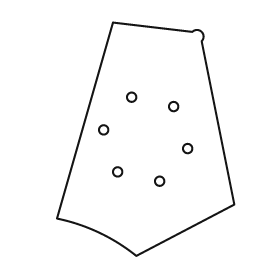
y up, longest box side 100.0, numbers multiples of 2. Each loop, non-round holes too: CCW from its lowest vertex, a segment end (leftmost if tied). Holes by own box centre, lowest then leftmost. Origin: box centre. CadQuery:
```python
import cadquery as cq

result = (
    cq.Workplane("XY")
    .moveTo(-4.0, -50.0)
    .lineTo(38.0, -28.0)
    .lineTo(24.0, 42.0)
    .threePointArc((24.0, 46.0), (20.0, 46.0))
    .lineTo(-14.0, 50.0)
    .lineTo(-38.0, -34.0)
    .threePointArc((-20.0, -40.0), (-4.0, -50.0))
    .close()
    .moveTo(6.0, -18.0)
    .circle(2.0)
    .moveTo(-12.0, -14.0)
    .circle(2.0)
    .moveTo(18.0, -4.0)
    .circle(2.0)
    .moveTo(-18.0, 4.0)
    .circle(2.0)
    .moveTo(12.0, 14.0)
    .circle(2.0)
    .moveTo(-6.0, 18.0)
    .circle(2.0)
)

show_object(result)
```